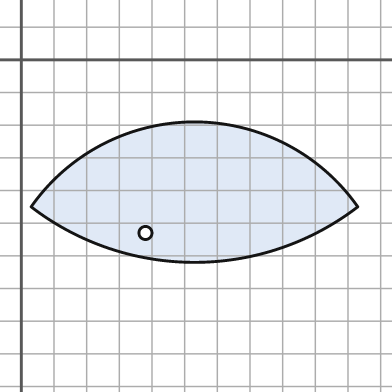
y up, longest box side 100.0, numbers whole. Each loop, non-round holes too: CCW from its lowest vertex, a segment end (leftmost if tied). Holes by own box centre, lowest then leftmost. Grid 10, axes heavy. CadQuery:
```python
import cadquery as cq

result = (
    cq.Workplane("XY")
    .moveTo(3.0, -45.0)
    .threePointArc((53.0, -62.0), (103.0, -45.0))
    .threePointArc((53.0, -19.0), (3.0, -45.0))
    .close()
    .moveTo(38.0, -53.0)
    .circle(2.0)
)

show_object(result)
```